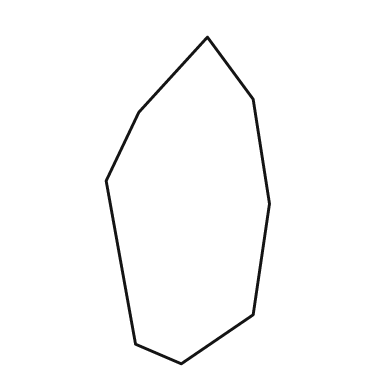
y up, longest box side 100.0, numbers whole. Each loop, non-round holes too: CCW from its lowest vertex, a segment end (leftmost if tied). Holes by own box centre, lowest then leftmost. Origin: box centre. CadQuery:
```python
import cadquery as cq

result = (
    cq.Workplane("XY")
    .moveTo(-2.0, -50.0)
    .lineTo(20.0, -35.0)
    .lineTo(25.0, -1.0)
    .lineTo(20.0, 31.0)
    .lineTo(6.0, 50.0)
    .lineTo(-15.0, 27.0)
    .lineTo(-25.0, 6.0)
    .lineTo(-16.0, -44.0)
    .close()
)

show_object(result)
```